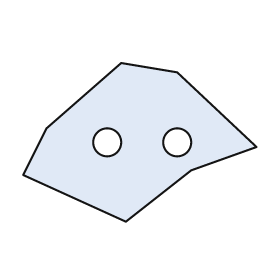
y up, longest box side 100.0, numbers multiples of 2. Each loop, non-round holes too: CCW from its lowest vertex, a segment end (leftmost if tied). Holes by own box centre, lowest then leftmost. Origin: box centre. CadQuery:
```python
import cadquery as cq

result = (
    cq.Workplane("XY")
    .moveTo(-6.0, -34.0)
    .lineTo(22.0, -12.0)
    .lineTo(50.0, -2.0)
    .lineTo(16.0, 30.0)
    .lineTo(-8.0, 34.0)
    .lineTo(-40.0, 6.0)
    .lineTo(-50.0, -14.0)
    .close()
    .moveTo(-14.0, 0.0)
    .circle(6.0)
    .moveTo(16.0, 0.0)
    .circle(6.0)
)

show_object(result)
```